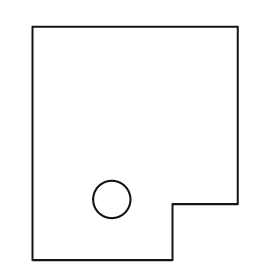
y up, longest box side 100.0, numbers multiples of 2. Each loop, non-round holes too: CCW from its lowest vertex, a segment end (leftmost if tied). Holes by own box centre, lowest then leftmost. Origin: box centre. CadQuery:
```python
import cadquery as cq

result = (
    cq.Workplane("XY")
    .moveTo(-44.0, -50.0)
    .lineTo(16.0, -50.0)
    .lineTo(16.0, -26.0)
    .lineTo(44.0, -26.0)
    .lineTo(44.0, 50.0)
    .lineTo(-44.0, 50.0)
    .close()
    .moveTo(-10.0, -24.0)
    .circle(8.0)
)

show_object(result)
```